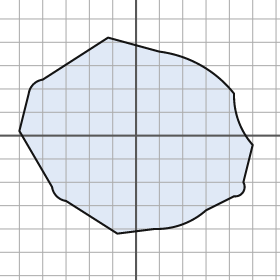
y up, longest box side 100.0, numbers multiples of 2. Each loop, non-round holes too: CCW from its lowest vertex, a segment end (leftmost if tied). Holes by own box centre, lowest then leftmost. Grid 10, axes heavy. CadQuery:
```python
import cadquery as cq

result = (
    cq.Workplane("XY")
    .moveTo(-8.0, -42.0)
    .lineTo(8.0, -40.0)
    .threePointArc((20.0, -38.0), (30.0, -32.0))
    .lineTo(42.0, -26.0)
    .threePointArc((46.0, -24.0), (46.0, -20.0))
    .lineTo(50.0, -4.0)
    .threePointArc((44.0, 6.0), (42.0, 18.0))
    .threePointArc((28.0, 30.0), (10.0, 36.0))
    .lineTo(-12.0, 42.0)
    .lineTo(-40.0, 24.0)
    .threePointArc((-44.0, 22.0), (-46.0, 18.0))
    .lineTo(-50.0, 2.0)
    .lineTo(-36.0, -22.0)
    .threePointArc((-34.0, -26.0), (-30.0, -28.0))
    .close()
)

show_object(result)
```